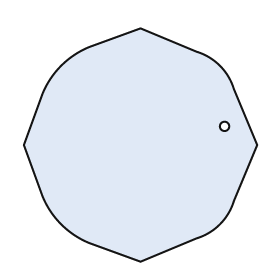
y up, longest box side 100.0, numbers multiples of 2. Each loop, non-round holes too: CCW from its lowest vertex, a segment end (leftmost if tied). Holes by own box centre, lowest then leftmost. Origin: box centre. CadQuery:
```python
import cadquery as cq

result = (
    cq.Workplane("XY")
    .moveTo(0.0, -50.0)
    .lineTo(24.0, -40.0)
    .threePointArc((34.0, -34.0), (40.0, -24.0))
    .lineTo(50.0, 0.0)
    .lineTo(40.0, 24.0)
    .threePointArc((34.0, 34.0), (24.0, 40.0))
    .lineTo(0.0, 50.0)
    .lineTo(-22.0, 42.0)
    .threePointArc((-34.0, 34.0), (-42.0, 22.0))
    .lineTo(-50.0, 0.0)
    .lineTo(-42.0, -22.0)
    .threePointArc((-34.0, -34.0), (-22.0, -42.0))
    .close()
    .moveTo(36.0, 8.0)
    .circle(2.0)
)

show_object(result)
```